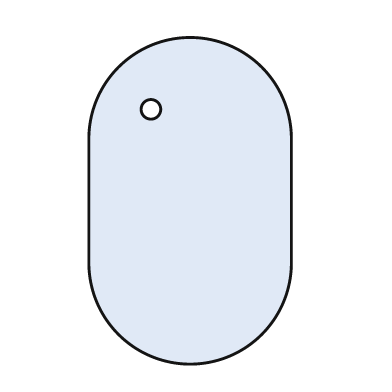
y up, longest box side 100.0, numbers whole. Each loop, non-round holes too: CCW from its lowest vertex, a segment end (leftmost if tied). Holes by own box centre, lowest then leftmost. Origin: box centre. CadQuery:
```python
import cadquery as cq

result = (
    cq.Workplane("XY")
    .moveTo(-31.0, -19.0)
    .threePointArc((0.0, -50.0), (31.0, -19.0))
    .lineTo(31.0, 19.0)
    .threePointArc((0.0, 50.0), (-31.0, 19.0))
    .close()
    .moveTo(-12.0, 28.0)
    .circle(3.0)
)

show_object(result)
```